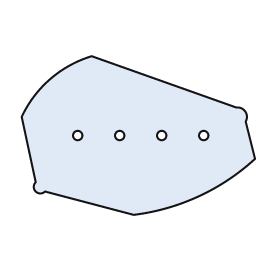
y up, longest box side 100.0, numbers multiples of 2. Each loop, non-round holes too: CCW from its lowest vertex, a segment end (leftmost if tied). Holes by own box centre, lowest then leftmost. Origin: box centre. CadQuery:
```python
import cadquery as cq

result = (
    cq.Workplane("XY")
    .moveTo(-2.0, -34.0)
    .threePointArc((26.0, -26.0), (50.0, -10.0))
    .lineTo(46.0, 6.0)
    .threePointArc((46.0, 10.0), (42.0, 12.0))
    .lineTo(-20.0, 34.0)
    .threePointArc((-38.0, 24.0), (-50.0, 8.0))
    .lineTo(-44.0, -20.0)
    .threePointArc((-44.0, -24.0), (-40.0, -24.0))
    .close()
    .moveTo(-26.0, 0.0)
    .circle(2.0)
    .moveTo(-8.0, 0.0)
    .circle(2.0)
    .moveTo(10.0, 0.0)
    .circle(2.0)
    .moveTo(28.0, 0.0)
    .circle(2.0)
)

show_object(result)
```